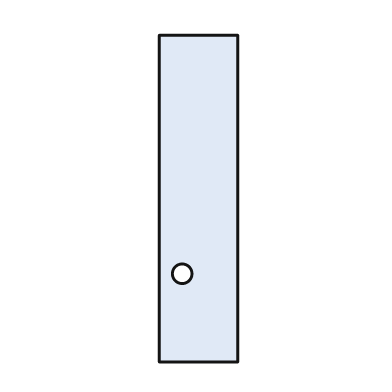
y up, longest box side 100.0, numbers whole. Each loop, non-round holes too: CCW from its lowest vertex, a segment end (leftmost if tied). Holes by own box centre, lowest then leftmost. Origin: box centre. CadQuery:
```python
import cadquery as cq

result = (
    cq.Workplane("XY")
    .moveTo(-12.0, -50.0)
    .lineTo(12.0, -50.0)
    .lineTo(12.0, 50.0)
    .lineTo(-12.0, 50.0)
    .close()
    .moveTo(-5.0, -23.0)
    .circle(3.0)
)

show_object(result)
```